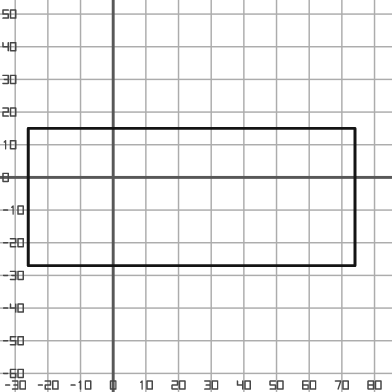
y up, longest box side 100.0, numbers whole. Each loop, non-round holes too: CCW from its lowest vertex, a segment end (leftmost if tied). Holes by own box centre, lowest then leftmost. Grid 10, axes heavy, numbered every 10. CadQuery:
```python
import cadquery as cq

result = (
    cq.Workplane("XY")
    .moveTo(-26.0, -27.0)
    .lineTo(74.0, -27.0)
    .lineTo(74.0, 15.0)
    .lineTo(-26.0, 15.0)
    .close()
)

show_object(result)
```